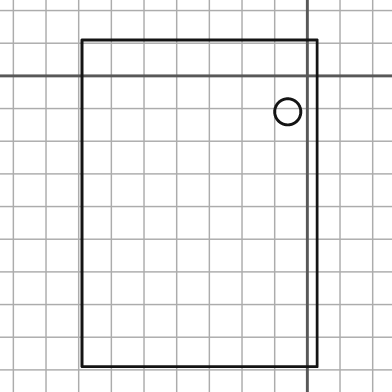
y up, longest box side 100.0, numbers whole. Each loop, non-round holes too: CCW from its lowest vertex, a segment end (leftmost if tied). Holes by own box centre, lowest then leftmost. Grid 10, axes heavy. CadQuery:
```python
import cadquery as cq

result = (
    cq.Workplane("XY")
    .moveTo(-69.0, -89.0)
    .lineTo(3.0, -89.0)
    .lineTo(3.0, 11.0)
    .lineTo(-69.0, 11.0)
    .close()
    .moveTo(-6.0, -11.0)
    .circle(4.0)
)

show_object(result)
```